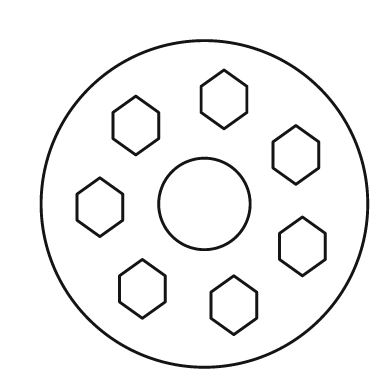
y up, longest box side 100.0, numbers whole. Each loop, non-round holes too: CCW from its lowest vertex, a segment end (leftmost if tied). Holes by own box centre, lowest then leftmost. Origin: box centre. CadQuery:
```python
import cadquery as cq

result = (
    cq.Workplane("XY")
    .moveTo(0.0, 0.0)
    .circle(50.0)
    .moveTo(9.0, -40.0)
    .lineTo(16.0, -35.0)
    .lineTo(16.0, -27.0)
    .lineTo(9.0, -22.0)
    .lineTo(2.0, -27.0)
    .lineTo(2.0, -35.0)
    .close()
    .moveTo(-19.0, -35.0)
    .lineTo(-12.0, -30.0)
    .lineTo(-12.0, -22.0)
    .lineTo(-19.0, -17.0)
    .lineTo(-26.0, -22.0)
    .lineTo(-26.0, -30.0)
    .close()
    .moveTo(30.0, -22.0)
    .lineTo(37.0, -17.0)
    .lineTo(37.0, -9.0)
    .lineTo(30.0, -4.0)
    .lineTo(23.0, -9.0)
    .lineTo(23.0, -17.0)
    .close()
    .moveTo(-32.0, -10.0)
    .lineTo(-25.0, -5.0)
    .lineTo(-25.0, 3.0)
    .lineTo(-32.0, 8.0)
    .lineTo(-39.0, 3.0)
    .lineTo(-39.0, -5.0)
    .close()
    .moveTo(0.0, 0.0)
    .circle(14.0)
    .moveTo(28.0, 6.0)
    .lineTo(35.0, 11.0)
    .lineTo(35.0, 19.0)
    .lineTo(28.0, 24.0)
    .lineTo(21.0, 19.0)
    .lineTo(21.0, 11.0)
    .close()
    .moveTo(-21.0, 15.0)
    .lineTo(-14.0, 20.0)
    .lineTo(-14.0, 28.0)
    .lineTo(-21.0, 33.0)
    .lineTo(-28.0, 28.0)
    .lineTo(-28.0, 20.0)
    .close()
    .moveTo(6.0, 23.0)
    .lineTo(13.0, 28.0)
    .lineTo(13.0, 36.0)
    .lineTo(6.0, 41.0)
    .lineTo(-1.0, 36.0)
    .lineTo(-1.0, 28.0)
    .close()
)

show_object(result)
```